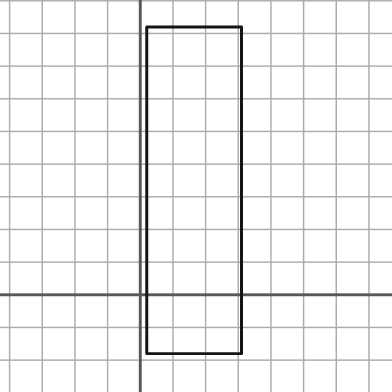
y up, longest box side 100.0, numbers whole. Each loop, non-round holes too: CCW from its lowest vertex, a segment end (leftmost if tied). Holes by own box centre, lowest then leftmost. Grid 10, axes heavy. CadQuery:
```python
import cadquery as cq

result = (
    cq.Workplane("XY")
    .moveTo(2.0, -18.0)
    .lineTo(31.0, -18.0)
    .lineTo(31.0, 82.0)
    .lineTo(2.0, 82.0)
    .close()
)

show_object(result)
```